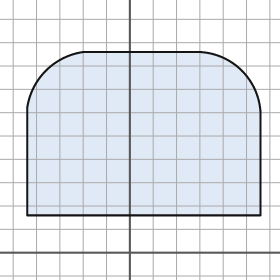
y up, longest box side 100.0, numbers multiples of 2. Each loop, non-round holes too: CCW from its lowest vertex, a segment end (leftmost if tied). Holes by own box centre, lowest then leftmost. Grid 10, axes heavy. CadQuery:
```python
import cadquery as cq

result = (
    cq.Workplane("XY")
    .moveTo(-44.0, 16.0)
    .lineTo(56.0, 16.0)
    .lineTo(56.0, 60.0)
    .threePointArc((48.0, 78.0), (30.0, 86.0))
    .lineTo(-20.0, 86.0)
    .threePointArc((-36.0, 78.0), (-44.0, 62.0))
    .close()
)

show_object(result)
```